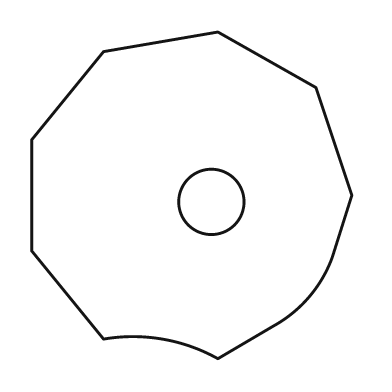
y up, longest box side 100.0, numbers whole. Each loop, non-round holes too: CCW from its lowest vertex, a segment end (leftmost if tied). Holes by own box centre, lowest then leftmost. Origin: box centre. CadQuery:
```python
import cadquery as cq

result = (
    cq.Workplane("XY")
    .moveTo(8.0, -50.0)
    .lineTo(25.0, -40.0)
    .threePointArc((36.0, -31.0), (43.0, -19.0))
    .lineTo(49.0, 0.0)
    .lineTo(38.0, 33.0)
    .lineTo(8.0, 50.0)
    .lineTo(-27.0, 44.0)
    .lineTo(-49.0, 17.0)
    .lineTo(-49.0, -17.0)
    .lineTo(-27.0, -44.0)
    .threePointArc((-9.0, -44.0), (8.0, -50.0))
    .close()
    .moveTo(6.0, -2.0)
    .circle(10.0)
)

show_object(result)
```